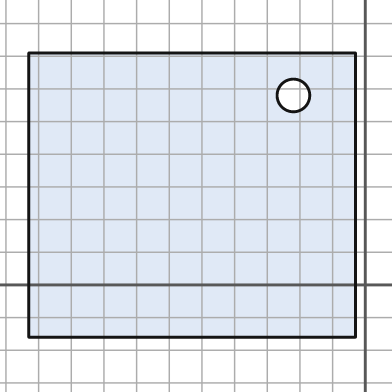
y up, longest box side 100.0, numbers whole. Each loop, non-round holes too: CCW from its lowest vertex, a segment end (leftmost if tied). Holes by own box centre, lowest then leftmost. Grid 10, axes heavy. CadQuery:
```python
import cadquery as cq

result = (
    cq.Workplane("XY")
    .moveTo(-103.0, -16.0)
    .lineTo(-3.0, -16.0)
    .lineTo(-3.0, 71.0)
    .lineTo(-103.0, 71.0)
    .close()
    .moveTo(-22.0, 58.0)
    .circle(5.0)
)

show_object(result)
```